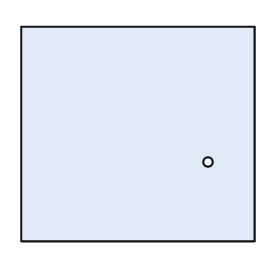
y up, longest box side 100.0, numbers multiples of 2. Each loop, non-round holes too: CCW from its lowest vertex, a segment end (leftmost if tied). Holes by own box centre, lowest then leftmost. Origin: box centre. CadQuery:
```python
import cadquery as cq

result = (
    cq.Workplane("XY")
    .moveTo(-50.0, -46.0)
    .lineTo(50.0, -46.0)
    .lineTo(50.0, 46.0)
    .lineTo(-50.0, 46.0)
    .close()
    .moveTo(30.0, -12.0)
    .circle(2.0)
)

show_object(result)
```